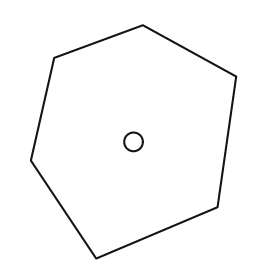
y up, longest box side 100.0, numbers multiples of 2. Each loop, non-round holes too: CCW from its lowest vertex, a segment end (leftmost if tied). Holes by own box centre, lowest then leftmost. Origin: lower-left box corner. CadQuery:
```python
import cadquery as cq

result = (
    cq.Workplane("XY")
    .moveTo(28.0, 0.0)
    .lineTo(80.0, 22.0)
    .lineTo(88.0, 78.0)
    .lineTo(48.0, 100.0)
    .lineTo(10.0, 86.0)
    .lineTo(0.0, 42.0)
    .close()
    .moveTo(44.0, 50.0)
    .circle(4.0)
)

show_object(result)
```